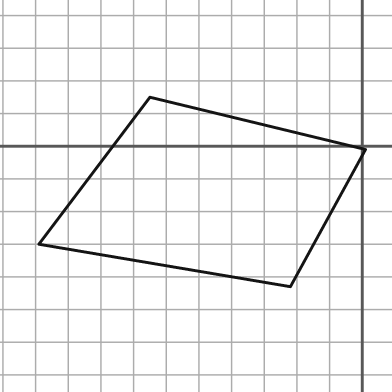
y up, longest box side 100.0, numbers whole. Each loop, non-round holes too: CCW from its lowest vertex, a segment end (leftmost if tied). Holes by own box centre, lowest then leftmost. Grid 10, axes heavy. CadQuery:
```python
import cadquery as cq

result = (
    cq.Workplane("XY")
    .moveTo(-22.0, -43.0)
    .lineTo(1.0, -1.0)
    .lineTo(-65.0, 15.0)
    .lineTo(-99.0, -30.0)
    .close()
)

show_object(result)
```